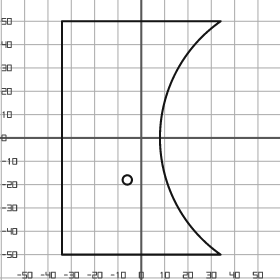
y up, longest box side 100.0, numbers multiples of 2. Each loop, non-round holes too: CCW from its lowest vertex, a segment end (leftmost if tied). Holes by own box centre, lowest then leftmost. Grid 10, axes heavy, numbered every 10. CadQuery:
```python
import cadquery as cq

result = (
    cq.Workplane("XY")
    .moveTo(-34.0, -50.0)
    .lineTo(34.0, -50.0)
    .threePointArc((8.0, 0.0), (34.0, 50.0))
    .lineTo(-34.0, 50.0)
    .close()
    .moveTo(-6.0, -18.0)
    .circle(2.0)
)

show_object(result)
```